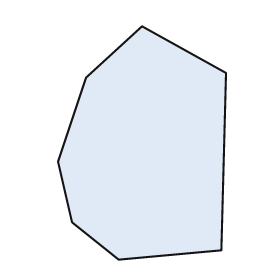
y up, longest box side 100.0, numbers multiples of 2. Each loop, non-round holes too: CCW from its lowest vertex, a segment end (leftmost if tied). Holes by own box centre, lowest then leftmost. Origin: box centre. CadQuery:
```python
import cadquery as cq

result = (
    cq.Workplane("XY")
    .moveTo(-10.0, -50.0)
    .lineTo(34.0, -46.0)
    .lineTo(36.0, 30.0)
    .lineTo(0.0, 50.0)
    .lineTo(-24.0, 28.0)
    .lineTo(-36.0, -8.0)
    .lineTo(-30.0, -34.0)
    .close()
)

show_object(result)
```